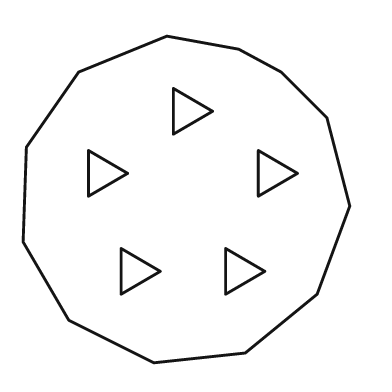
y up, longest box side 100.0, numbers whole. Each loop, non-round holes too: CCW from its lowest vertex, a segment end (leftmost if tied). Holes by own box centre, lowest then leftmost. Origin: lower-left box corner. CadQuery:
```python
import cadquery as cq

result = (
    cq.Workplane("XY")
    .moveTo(40.0, 0.0)
    .lineTo(68.0, 3.0)
    .lineTo(90.0, 21.0)
    .lineTo(100.0, 48.0)
    .lineTo(93.0, 75.0)
    .lineTo(79.0, 89.0)
    .lineTo(66.0, 96.0)
    .lineTo(44.0, 100.0)
    .lineTo(17.0, 89.0)
    .lineTo(1.0, 66.0)
    .lineTo(0.0, 37.0)
    .lineTo(14.0, 13.0)
    .close()
    .moveTo(30.0, 21.0)
    .lineTo(42.0, 28.0)
    .lineTo(30.0, 35.0)
    .close()
    .moveTo(62.0, 21.0)
    .lineTo(74.0, 28.0)
    .lineTo(62.0, 35.0)
    .close()
    .moveTo(20.0, 51.0)
    .lineTo(32.0, 58.0)
    .lineTo(20.0, 65.0)
    .close()
    .moveTo(72.0, 51.0)
    .lineTo(84.0, 58.0)
    .lineTo(72.0, 65.0)
    .close()
    .moveTo(46.0, 70.0)
    .lineTo(58.0, 77.0)
    .lineTo(46.0, 84.0)
    .close()
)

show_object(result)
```